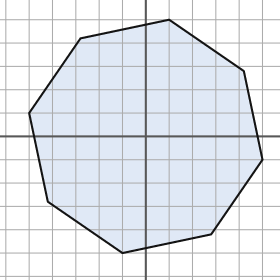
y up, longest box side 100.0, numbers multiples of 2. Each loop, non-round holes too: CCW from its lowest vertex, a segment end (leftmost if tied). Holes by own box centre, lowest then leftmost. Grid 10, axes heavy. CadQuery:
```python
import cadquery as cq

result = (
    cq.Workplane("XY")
    .moveTo(-10.0, -50.0)
    .lineTo(28.0, -42.0)
    .lineTo(50.0, -10.0)
    .lineTo(42.0, 28.0)
    .lineTo(10.0, 50.0)
    .lineTo(-28.0, 42.0)
    .lineTo(-50.0, 10.0)
    .lineTo(-42.0, -28.0)
    .close()
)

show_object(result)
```